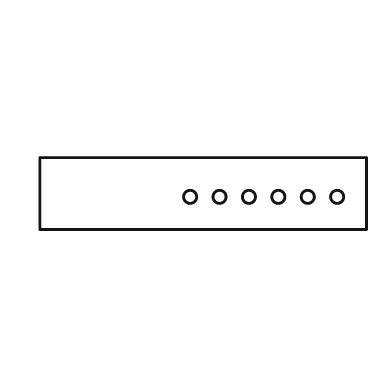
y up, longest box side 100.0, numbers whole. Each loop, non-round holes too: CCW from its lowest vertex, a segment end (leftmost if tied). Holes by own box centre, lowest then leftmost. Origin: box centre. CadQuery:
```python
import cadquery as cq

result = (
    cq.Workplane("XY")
    .moveTo(-50.0, -11.0)
    .lineTo(50.0, -11.0)
    .lineTo(50.0, 11.0)
    .lineTo(-50.0, 11.0)
    .close()
    .moveTo(-4.0, -1.0)
    .circle(2.0)
    .moveTo(5.0, -1.0)
    .circle(2.0)
    .moveTo(14.0, -1.0)
    .circle(2.0)
    .moveTo(23.0, -1.0)
    .circle(2.0)
    .moveTo(32.0, -1.0)
    .circle(2.0)
    .moveTo(41.0, -1.0)
    .circle(2.0)
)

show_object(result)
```